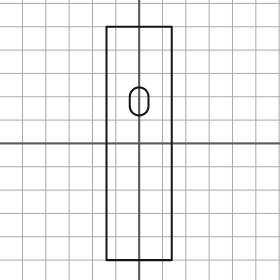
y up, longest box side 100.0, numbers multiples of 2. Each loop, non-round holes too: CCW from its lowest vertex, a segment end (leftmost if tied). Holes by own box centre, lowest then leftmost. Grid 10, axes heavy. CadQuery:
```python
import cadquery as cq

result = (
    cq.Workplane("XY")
    .moveTo(-14.0, -50.0)
    .lineTo(14.0, -50.0)
    .lineTo(14.0, 50.0)
    .lineTo(-14.0, 50.0)
    .close()
    .moveTo(-4.0, 16.0)
    .threePointArc((0.0, 12.0), (4.0, 16.0))
    .lineTo(4.0, 20.0)
    .threePointArc((0.0, 24.0), (-4.0, 20.0))
    .close()
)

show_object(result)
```